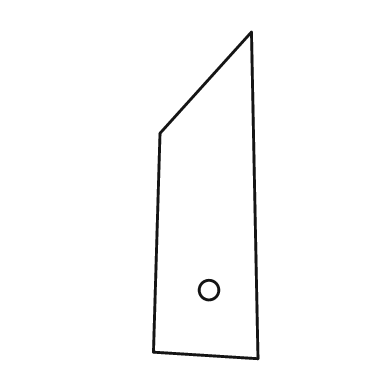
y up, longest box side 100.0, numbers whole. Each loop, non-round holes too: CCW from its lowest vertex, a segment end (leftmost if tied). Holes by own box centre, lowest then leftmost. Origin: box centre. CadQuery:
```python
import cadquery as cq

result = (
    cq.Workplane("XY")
    .moveTo(16.0, -50.0)
    .lineTo(14.0, 50.0)
    .lineTo(-14.0, 19.0)
    .lineTo(-16.0, -48.0)
    .close()
    .moveTo(1.0, -29.0)
    .circle(3.0)
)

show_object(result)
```